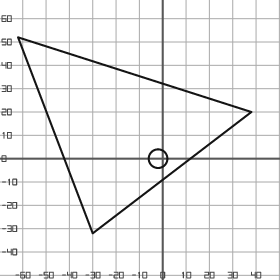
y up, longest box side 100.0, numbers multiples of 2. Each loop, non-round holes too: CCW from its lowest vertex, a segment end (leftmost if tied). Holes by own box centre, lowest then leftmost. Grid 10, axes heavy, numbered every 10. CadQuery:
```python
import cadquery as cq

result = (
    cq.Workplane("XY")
    .moveTo(-30.0, -32.0)
    .lineTo(38.0, 20.0)
    .lineTo(-62.0, 52.0)
    .close()
    .moveTo(-2.0, 0.0)
    .circle(4.0)
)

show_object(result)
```